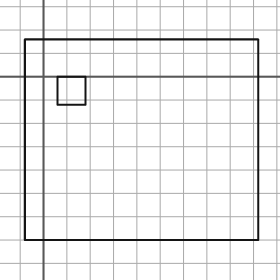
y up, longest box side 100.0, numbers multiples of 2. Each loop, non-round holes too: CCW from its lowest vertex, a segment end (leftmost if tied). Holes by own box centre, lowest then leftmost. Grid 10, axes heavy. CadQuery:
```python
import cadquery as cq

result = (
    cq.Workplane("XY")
    .moveTo(-8.0, -70.0)
    .lineTo(92.0, -70.0)
    .lineTo(92.0, 16.0)
    .lineTo(-8.0, 16.0)
    .close()
    .moveTo(6.0, -12.0)
    .lineTo(18.0, -12.0)
    .lineTo(18.0, 0.0)
    .lineTo(6.0, 0.0)
    .close()
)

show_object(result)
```